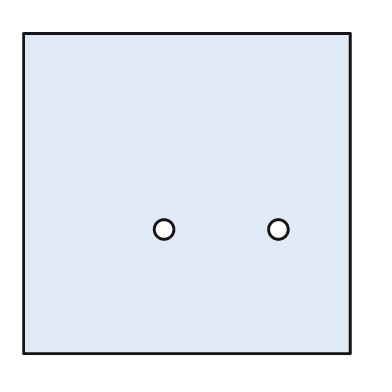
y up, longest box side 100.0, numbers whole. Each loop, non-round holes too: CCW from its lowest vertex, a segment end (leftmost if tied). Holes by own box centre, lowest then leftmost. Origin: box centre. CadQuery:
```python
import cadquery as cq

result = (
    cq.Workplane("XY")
    .moveTo(-50.0, -49.0)
    .lineTo(50.0, -49.0)
    .lineTo(50.0, 49.0)
    .lineTo(-50.0, 49.0)
    .close()
    .moveTo(-7.0, -11.0)
    .circle(3.0)
    .moveTo(28.0, -11.0)
    .circle(3.0)
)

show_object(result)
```